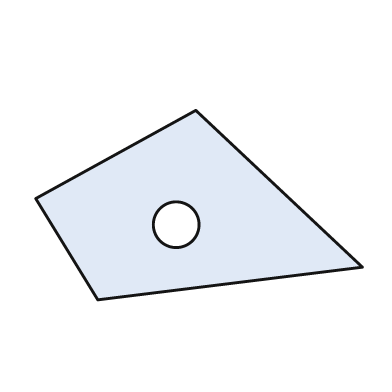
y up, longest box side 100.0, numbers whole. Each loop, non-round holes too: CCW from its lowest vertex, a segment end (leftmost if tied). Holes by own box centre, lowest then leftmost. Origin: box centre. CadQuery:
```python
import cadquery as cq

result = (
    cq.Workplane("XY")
    .moveTo(-31.0, -29.0)
    .lineTo(50.0, -19.0)
    .lineTo(-1.0, 29.0)
    .lineTo(-50.0, 2.0)
    .close()
    .moveTo(-7.0, -6.0)
    .circle(7.0)
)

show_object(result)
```